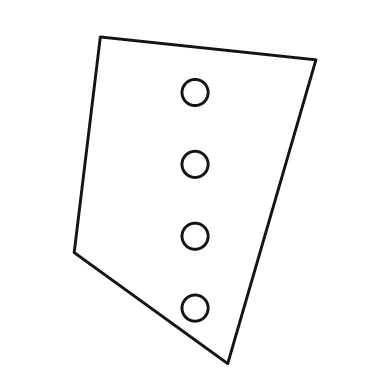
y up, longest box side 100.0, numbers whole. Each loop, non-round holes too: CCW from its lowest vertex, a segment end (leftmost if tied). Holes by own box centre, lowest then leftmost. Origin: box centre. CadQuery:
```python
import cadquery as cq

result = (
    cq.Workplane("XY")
    .moveTo(10.0, -50.0)
    .lineTo(37.0, 43.0)
    .lineTo(-29.0, 50.0)
    .lineTo(-37.0, -16.0)
    .close()
    .moveTo(0.0, -33.0)
    .circle(4.0)
    .moveTo(0.0, -11.0)
    .circle(4.0)
    .moveTo(0.0, 11.0)
    .circle(4.0)
    .moveTo(0.0, 33.0)
    .circle(4.0)
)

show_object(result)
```